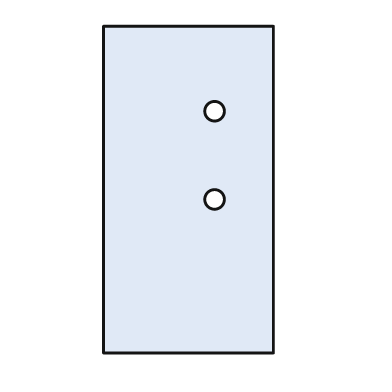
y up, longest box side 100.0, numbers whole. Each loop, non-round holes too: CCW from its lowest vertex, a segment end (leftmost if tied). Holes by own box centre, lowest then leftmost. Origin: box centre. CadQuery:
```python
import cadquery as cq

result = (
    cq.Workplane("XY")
    .moveTo(-26.0, -50.0)
    .lineTo(26.0, -50.0)
    .lineTo(26.0, 50.0)
    .lineTo(-26.0, 50.0)
    .close()
    .moveTo(8.0, -3.0)
    .circle(3.0)
    .moveTo(8.0, 24.0)
    .circle(3.0)
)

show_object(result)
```